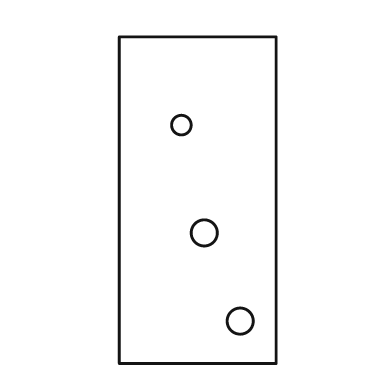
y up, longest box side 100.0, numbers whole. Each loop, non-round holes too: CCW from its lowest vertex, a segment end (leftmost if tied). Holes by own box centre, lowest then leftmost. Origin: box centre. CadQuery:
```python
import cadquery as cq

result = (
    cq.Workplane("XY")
    .moveTo(-24.0, -50.0)
    .lineTo(24.0, -50.0)
    .lineTo(24.0, 50.0)
    .lineTo(-24.0, 50.0)
    .close()
    .moveTo(13.0, -37.0)
    .circle(4.0)
    .moveTo(2.0, -10.0)
    .circle(4.0)
    .moveTo(-5.0, 23.0)
    .circle(3.0)
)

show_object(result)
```